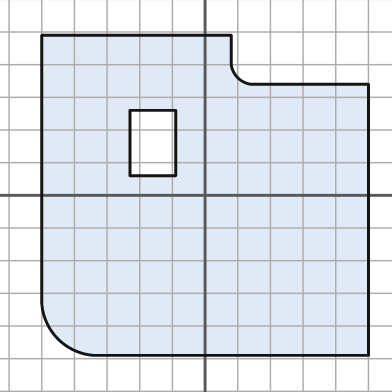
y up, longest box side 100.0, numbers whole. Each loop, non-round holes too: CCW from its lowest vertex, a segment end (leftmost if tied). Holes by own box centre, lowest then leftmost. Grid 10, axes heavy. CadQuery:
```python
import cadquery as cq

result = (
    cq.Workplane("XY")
    .moveTo(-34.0, -49.0)
    .lineTo(50.0, -49.0)
    .lineTo(50.0, 34.0)
    .lineTo(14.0, 34.0)
    .threePointArc((10.0, 36.0), (8.0, 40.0))
    .lineTo(8.0, 49.0)
    .lineTo(-50.0, 49.0)
    .lineTo(-50.0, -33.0)
    .threePointArc((-45.0, -44.0), (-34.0, -49.0))
    .close()
    .moveTo(-23.0, 6.0)
    .lineTo(-9.0, 6.0)
    .lineTo(-9.0, 26.0)
    .lineTo(-23.0, 26.0)
    .close()
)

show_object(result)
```